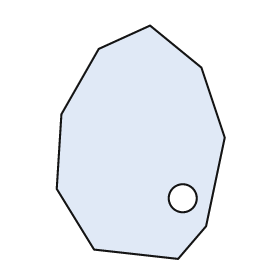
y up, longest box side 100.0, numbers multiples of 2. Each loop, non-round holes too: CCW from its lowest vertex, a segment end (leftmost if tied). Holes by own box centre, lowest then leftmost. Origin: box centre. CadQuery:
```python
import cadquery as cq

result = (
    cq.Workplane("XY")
    .moveTo(16.0, -50.0)
    .lineTo(28.0, -36.0)
    .lineTo(36.0, 2.0)
    .lineTo(26.0, 32.0)
    .lineTo(4.0, 50.0)
    .lineTo(-18.0, 40.0)
    .lineTo(-34.0, 12.0)
    .lineTo(-36.0, -20.0)
    .lineTo(-20.0, -46.0)
    .close()
    .moveTo(18.0, -24.0)
    .circle(6.0)
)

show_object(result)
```